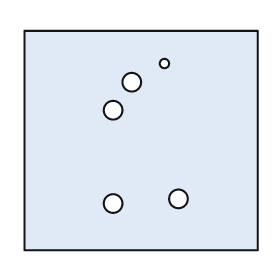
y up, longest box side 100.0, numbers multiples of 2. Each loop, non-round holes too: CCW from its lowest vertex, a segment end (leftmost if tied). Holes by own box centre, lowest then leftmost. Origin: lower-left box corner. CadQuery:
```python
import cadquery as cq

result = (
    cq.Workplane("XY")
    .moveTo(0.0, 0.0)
    .lineTo(100.0, 0.0)
    .lineTo(100.0, 94.0)
    .lineTo(0.0, 94.0)
    .close()
    .moveTo(38.0, 20.0)
    .circle(4.0)
    .moveTo(66.0, 22.0)
    .circle(4.0)
    .moveTo(38.0, 60.0)
    .circle(4.0)
    .moveTo(46.0, 72.0)
    .circle(4.0)
    .moveTo(60.0, 80.0)
    .circle(2.0)
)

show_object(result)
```